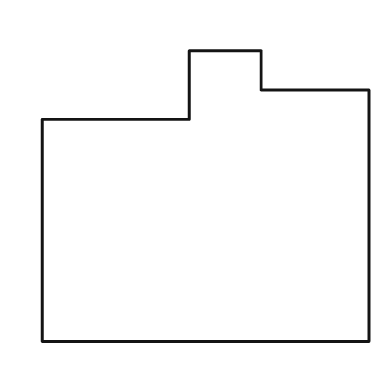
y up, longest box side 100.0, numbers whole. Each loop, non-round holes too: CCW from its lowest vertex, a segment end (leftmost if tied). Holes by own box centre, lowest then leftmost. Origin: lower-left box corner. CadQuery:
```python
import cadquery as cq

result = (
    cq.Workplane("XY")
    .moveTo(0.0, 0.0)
    .lineTo(100.0, 0.0)
    .lineTo(100.0, 77.0)
    .lineTo(67.0, 77.0)
    .lineTo(67.0, 89.0)
    .lineTo(45.0, 89.0)
    .lineTo(45.0, 68.0)
    .lineTo(0.0, 68.0)
    .close()
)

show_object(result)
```